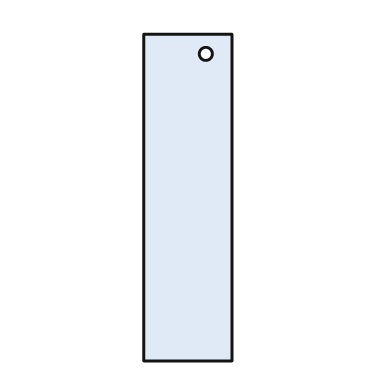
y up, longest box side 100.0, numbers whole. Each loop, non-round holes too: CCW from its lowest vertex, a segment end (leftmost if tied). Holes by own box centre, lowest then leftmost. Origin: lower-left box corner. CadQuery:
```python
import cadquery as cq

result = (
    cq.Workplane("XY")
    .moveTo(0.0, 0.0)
    .lineTo(27.0, 0.0)
    .lineTo(27.0, 100.0)
    .lineTo(0.0, 100.0)
    .close()
    .moveTo(19.0, 94.0)
    .circle(2.0)
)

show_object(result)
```